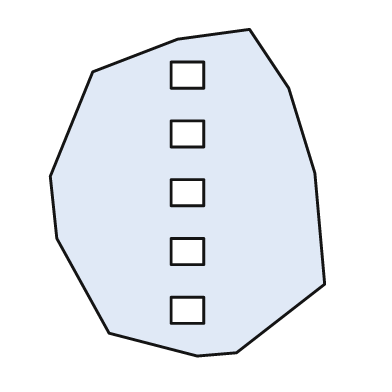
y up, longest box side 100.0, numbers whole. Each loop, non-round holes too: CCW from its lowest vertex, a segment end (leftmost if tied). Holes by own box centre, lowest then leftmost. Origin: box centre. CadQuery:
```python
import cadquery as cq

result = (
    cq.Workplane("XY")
    .moveTo(3.0, -50.0)
    .lineTo(15.0, -49.0)
    .lineTo(42.0, -28.0)
    .lineTo(39.0, 6.0)
    .lineTo(31.0, 32.0)
    .lineTo(19.0, 50.0)
    .lineTo(-3.0, 47.0)
    .lineTo(-29.0, 37.0)
    .lineTo(-42.0, 5.0)
    .lineTo(-40.0, -14.0)
    .lineTo(-24.0, -43.0)
    .close()
    .moveTo(-5.0, -40.0)
    .lineTo(5.0, -40.0)
    .lineTo(5.0, -32.0)
    .lineTo(-5.0, -32.0)
    .close()
    .moveTo(-5.0, -22.0)
    .lineTo(5.0, -22.0)
    .lineTo(5.0, -14.0)
    .lineTo(-5.0, -14.0)
    .close()
    .moveTo(-5.0, -4.0)
    .lineTo(5.0, -4.0)
    .lineTo(5.0, 4.0)
    .lineTo(-5.0, 4.0)
    .close()
    .moveTo(-5.0, 14.0)
    .lineTo(5.0, 14.0)
    .lineTo(5.0, 22.0)
    .lineTo(-5.0, 22.0)
    .close()
    .moveTo(-5.0, 32.0)
    .lineTo(5.0, 32.0)
    .lineTo(5.0, 40.0)
    .lineTo(-5.0, 40.0)
    .close()
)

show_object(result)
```